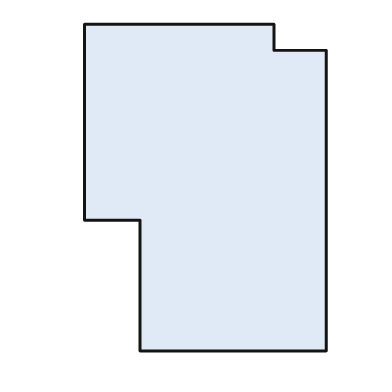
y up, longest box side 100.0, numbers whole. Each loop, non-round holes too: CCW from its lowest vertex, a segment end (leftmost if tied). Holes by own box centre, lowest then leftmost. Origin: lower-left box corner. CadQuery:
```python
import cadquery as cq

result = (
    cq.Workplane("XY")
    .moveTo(17.0, 0.0)
    .lineTo(74.0, 0.0)
    .lineTo(74.0, 92.0)
    .lineTo(58.0, 92.0)
    .lineTo(58.0, 100.0)
    .lineTo(0.0, 100.0)
    .lineTo(0.0, 40.0)
    .lineTo(17.0, 40.0)
    .close()
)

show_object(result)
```